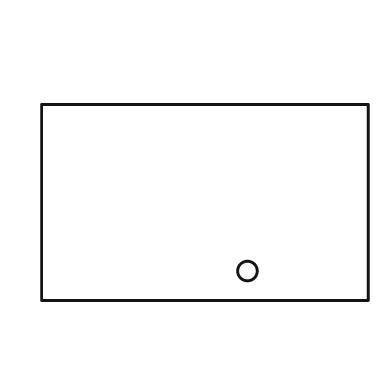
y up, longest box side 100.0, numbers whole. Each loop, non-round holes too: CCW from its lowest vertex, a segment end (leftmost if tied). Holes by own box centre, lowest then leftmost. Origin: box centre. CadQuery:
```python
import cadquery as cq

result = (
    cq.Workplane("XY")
    .moveTo(-50.0, -30.0)
    .lineTo(50.0, -30.0)
    .lineTo(50.0, 30.0)
    .lineTo(-50.0, 30.0)
    .close()
    .moveTo(13.0, -21.0)
    .circle(3.0)
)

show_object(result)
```